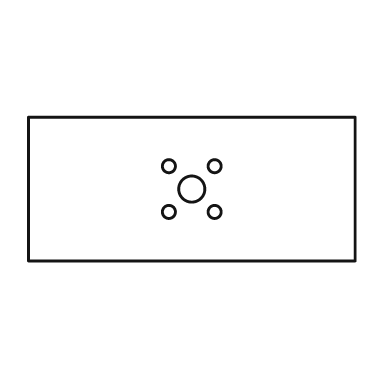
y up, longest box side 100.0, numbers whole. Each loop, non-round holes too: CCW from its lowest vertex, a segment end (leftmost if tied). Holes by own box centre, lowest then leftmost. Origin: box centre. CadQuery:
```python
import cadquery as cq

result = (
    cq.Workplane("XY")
    .moveTo(-50.0, -22.0)
    .lineTo(50.0, -22.0)
    .lineTo(50.0, 22.0)
    .lineTo(-50.0, 22.0)
    .close()
    .moveTo(-7.0, -7.0)
    .circle(2.0)
    .moveTo(7.0, -7.0)
    .circle(2.0)
    .moveTo(0.0, 0.0)
    .circle(4.0)
    .moveTo(-7.0, 7.0)
    .circle(2.0)
    .moveTo(7.0, 7.0)
    .circle(2.0)
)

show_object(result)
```